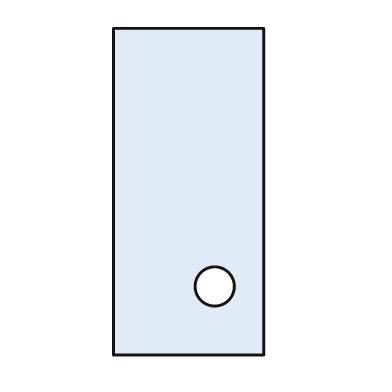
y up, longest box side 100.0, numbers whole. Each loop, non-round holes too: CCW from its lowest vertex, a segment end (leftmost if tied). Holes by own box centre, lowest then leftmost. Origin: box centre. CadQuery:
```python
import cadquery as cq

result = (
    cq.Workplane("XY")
    .moveTo(-23.0, -50.0)
    .lineTo(23.0, -50.0)
    .lineTo(23.0, 50.0)
    .lineTo(-23.0, 50.0)
    .close()
    .moveTo(8.0, -29.0)
    .circle(6.0)
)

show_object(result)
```